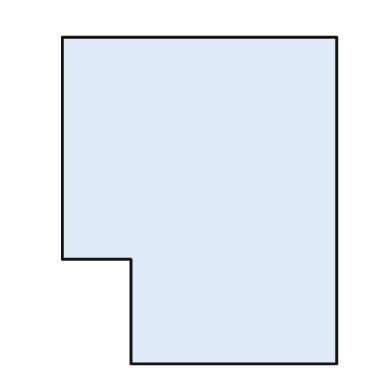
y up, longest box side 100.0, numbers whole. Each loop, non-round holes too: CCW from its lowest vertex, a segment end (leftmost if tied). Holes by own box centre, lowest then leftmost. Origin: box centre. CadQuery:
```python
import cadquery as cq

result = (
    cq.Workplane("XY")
    .moveTo(-21.0, -50.0)
    .lineTo(42.0, -50.0)
    .lineTo(42.0, 50.0)
    .lineTo(-42.0, 50.0)
    .lineTo(-42.0, -18.0)
    .lineTo(-21.0, -18.0)
    .close()
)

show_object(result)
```